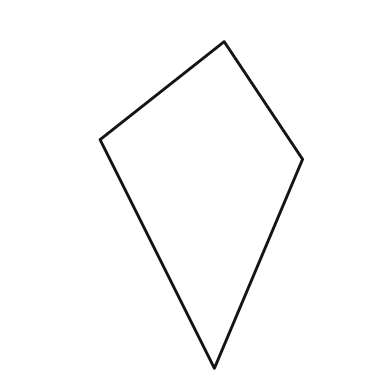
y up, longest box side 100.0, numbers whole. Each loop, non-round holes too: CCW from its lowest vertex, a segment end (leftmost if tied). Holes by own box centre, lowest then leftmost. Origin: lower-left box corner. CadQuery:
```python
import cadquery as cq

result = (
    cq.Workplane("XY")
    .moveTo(35.0, 0.0)
    .lineTo(62.0, 64.0)
    .lineTo(38.0, 100.0)
    .lineTo(0.0, 70.0)
    .close()
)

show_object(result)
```